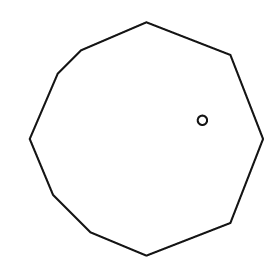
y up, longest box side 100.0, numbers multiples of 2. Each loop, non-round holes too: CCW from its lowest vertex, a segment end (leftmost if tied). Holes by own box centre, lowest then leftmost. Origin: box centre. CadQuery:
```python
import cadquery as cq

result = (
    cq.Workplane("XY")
    .moveTo(0.0, -50.0)
    .lineTo(36.0, -36.0)
    .lineTo(50.0, 0.0)
    .lineTo(36.0, 36.0)
    .lineTo(0.0, 50.0)
    .lineTo(-28.0, 38.0)
    .lineTo(-38.0, 28.0)
    .lineTo(-50.0, 0.0)
    .lineTo(-40.0, -24.0)
    .lineTo(-24.0, -40.0)
    .close()
    .moveTo(24.0, 8.0)
    .circle(2.0)
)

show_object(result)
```